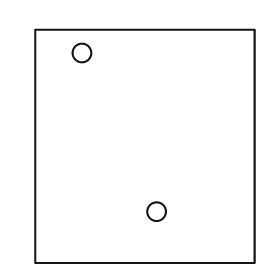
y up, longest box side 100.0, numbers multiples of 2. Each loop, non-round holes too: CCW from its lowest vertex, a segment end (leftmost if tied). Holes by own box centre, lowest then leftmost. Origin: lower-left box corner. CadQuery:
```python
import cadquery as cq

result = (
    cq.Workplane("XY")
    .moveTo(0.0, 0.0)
    .lineTo(94.0, 0.0)
    .lineTo(94.0, 100.0)
    .lineTo(0.0, 100.0)
    .close()
    .moveTo(52.0, 22.0)
    .circle(4.0)
    .moveTo(20.0, 90.0)
    .circle(4.0)
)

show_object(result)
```